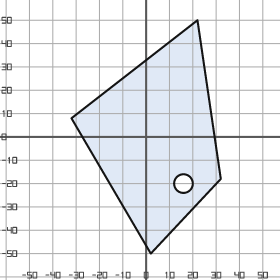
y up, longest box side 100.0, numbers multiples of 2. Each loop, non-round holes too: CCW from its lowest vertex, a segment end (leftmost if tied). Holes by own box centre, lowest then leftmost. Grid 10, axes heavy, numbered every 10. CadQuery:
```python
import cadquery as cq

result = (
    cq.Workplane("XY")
    .moveTo(2.0, -50.0)
    .lineTo(32.0, -18.0)
    .lineTo(22.0, 50.0)
    .lineTo(-32.0, 8.0)
    .close()
    .moveTo(16.0, -20.0)
    .circle(4.0)
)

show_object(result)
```